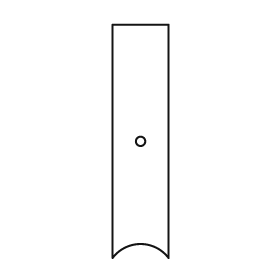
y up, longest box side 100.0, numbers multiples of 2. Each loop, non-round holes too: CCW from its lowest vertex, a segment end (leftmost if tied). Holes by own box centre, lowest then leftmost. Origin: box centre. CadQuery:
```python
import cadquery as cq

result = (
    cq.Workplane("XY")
    .moveTo(-12.0, -50.0)
    .threePointArc((0.0, -44.0), (12.0, -50.0))
    .lineTo(12.0, 50.0)
    .lineTo(-12.0, 50.0)
    .close()
    .moveTo(0.0, 0.0)
    .circle(2.0)
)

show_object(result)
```